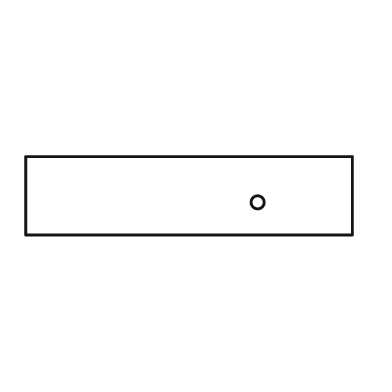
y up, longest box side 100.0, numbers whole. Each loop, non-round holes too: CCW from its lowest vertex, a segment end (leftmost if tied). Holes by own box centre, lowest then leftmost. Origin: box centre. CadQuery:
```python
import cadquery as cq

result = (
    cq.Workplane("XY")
    .moveTo(-50.0, -12.0)
    .lineTo(50.0, -12.0)
    .lineTo(50.0, 12.0)
    .lineTo(-50.0, 12.0)
    .close()
    .moveTo(21.0, -2.0)
    .circle(2.0)
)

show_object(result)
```